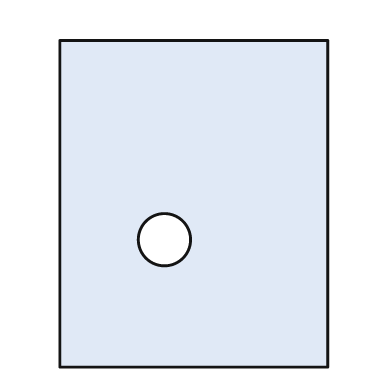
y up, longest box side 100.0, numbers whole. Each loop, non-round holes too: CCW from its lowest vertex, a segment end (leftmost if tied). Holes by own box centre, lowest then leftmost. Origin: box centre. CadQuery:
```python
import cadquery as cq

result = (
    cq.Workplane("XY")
    .moveTo(-41.0, -50.0)
    .lineTo(41.0, -50.0)
    .lineTo(41.0, 50.0)
    .lineTo(-41.0, 50.0)
    .close()
    .moveTo(-9.0, -11.0)
    .circle(8.0)
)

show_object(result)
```